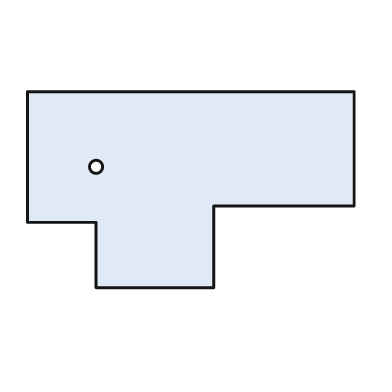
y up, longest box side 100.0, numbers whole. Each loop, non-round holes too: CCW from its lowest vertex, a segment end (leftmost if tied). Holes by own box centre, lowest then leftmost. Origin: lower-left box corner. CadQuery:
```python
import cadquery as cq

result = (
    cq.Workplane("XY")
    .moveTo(21.0, 0.0)
    .lineTo(57.0, 0.0)
    .lineTo(57.0, 25.0)
    .lineTo(100.0, 25.0)
    .lineTo(100.0, 60.0)
    .lineTo(0.0, 60.0)
    .lineTo(0.0, 20.0)
    .lineTo(21.0, 20.0)
    .close()
    .moveTo(21.0, 37.0)
    .circle(2.0)
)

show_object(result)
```